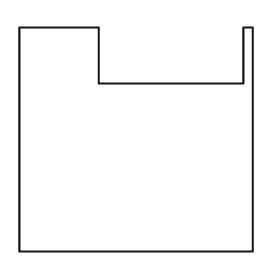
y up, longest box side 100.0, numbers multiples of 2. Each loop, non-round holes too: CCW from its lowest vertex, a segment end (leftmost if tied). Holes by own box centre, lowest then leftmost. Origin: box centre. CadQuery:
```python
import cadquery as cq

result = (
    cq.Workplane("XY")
    .moveTo(-50.0, -48.0)
    .lineTo(50.0, -48.0)
    .lineTo(50.0, 48.0)
    .lineTo(46.0, 48.0)
    .lineTo(46.0, 24.0)
    .lineTo(-16.0, 24.0)
    .lineTo(-16.0, 48.0)
    .lineTo(-50.0, 48.0)
    .close()
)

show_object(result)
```